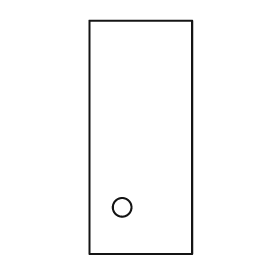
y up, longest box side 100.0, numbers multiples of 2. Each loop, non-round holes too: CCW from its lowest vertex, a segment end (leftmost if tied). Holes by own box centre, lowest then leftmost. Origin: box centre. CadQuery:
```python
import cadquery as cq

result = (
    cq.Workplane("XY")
    .moveTo(-22.0, -50.0)
    .lineTo(22.0, -50.0)
    .lineTo(22.0, 50.0)
    .lineTo(-22.0, 50.0)
    .close()
    .moveTo(-8.0, -30.0)
    .circle(4.0)
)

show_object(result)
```